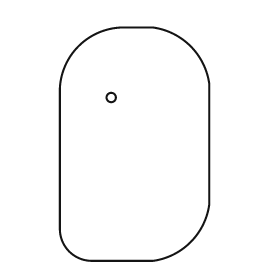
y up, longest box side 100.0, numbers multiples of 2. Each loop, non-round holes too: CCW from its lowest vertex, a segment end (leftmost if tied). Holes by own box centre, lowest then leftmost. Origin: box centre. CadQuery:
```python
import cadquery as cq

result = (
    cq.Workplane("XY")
    .moveTo(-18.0, -50.0)
    .lineTo(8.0, -50.0)
    .threePointArc((24.0, -42.0), (32.0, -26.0))
    .lineTo(32.0, 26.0)
    .threePointArc((24.0, 42.0), (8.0, 50.0))
    .lineTo(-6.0, 50.0)
    .threePointArc((-24.0, 42.0), (-32.0, 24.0))
    .lineTo(-32.0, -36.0)
    .threePointArc((-28.0, -46.0), (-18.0, -50.0))
    .close()
    .moveTo(-10.0, 20.0)
    .circle(2.0)
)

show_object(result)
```